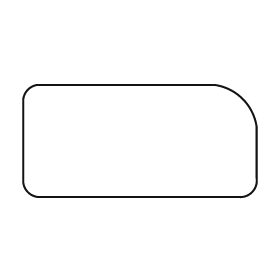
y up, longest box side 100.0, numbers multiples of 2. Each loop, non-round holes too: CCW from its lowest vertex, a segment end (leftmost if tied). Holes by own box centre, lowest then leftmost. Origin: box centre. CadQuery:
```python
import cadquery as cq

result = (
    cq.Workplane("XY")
    .moveTo(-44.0, -24.0)
    .lineTo(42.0, -24.0)
    .threePointArc((48.0, -22.0), (50.0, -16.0))
    .lineTo(50.0, 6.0)
    .threePointArc((44.0, 18.0), (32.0, 24.0))
    .lineTo(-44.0, 24.0)
    .threePointArc((-48.0, 22.0), (-50.0, 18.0))
    .lineTo(-50.0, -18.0)
    .threePointArc((-48.0, -22.0), (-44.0, -24.0))
    .close()
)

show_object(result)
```